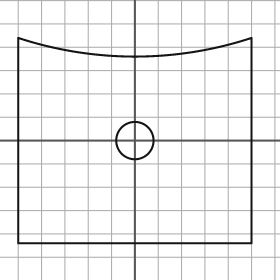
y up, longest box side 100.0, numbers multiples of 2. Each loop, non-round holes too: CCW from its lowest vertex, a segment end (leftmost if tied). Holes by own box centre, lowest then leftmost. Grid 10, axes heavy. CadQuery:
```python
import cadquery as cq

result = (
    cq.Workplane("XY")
    .moveTo(-50.0, -44.0)
    .lineTo(50.0, -44.0)
    .lineTo(50.0, 44.0)
    .threePointArc((0.0, 36.0), (-50.0, 44.0))
    .close()
    .moveTo(0.0, 0.0)
    .circle(8.0)
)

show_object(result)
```